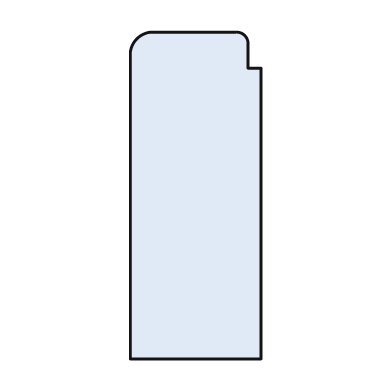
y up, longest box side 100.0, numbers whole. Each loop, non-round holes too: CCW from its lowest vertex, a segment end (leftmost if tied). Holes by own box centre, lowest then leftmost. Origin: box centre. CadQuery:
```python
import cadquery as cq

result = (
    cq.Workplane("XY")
    .moveTo(-20.0, -50.0)
    .lineTo(20.0, -50.0)
    .lineTo(20.0, 39.0)
    .lineTo(16.0, 39.0)
    .lineTo(16.0, 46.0)
    .threePointArc((15.0, 49.0), (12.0, 50.0))
    .lineTo(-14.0, 50.0)
    .threePointArc((-18.0, 48.0), (-20.0, 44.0))
    .close()
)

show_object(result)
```